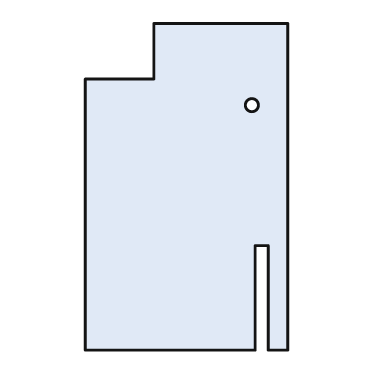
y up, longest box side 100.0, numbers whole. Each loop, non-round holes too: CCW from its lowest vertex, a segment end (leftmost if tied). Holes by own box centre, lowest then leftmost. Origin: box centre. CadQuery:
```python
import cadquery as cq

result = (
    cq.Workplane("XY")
    .moveTo(-31.0, -50.0)
    .lineTo(21.0, -50.0)
    .lineTo(21.0, -18.0)
    .lineTo(25.0, -18.0)
    .lineTo(25.0, -50.0)
    .lineTo(31.0, -50.0)
    .lineTo(31.0, 50.0)
    .lineTo(-10.0, 50.0)
    .lineTo(-10.0, 33.0)
    .lineTo(-31.0, 33.0)
    .close()
    .moveTo(20.0, 25.0)
    .circle(2.0)
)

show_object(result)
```